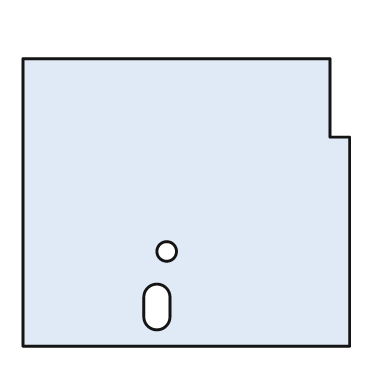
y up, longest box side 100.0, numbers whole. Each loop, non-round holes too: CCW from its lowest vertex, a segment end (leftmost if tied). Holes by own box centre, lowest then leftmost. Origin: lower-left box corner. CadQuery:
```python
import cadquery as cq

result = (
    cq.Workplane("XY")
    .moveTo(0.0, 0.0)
    .lineTo(100.0, 0.0)
    .lineTo(100.0, 64.0)
    .lineTo(94.0, 64.0)
    .lineTo(94.0, 88.0)
    .lineTo(0.0, 88.0)
    .close()
    .moveTo(37.0, 9.0)
    .threePointArc((41.0, 5.0), (45.0, 9.0))
    .lineTo(45.0, 15.0)
    .threePointArc((41.0, 19.0), (37.0, 15.0))
    .close()
    .moveTo(44.0, 29.0)
    .circle(3.0)
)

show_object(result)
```